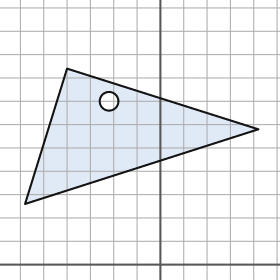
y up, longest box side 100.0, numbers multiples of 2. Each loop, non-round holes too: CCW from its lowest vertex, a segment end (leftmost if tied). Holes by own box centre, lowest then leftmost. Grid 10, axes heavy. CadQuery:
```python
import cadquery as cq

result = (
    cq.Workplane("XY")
    .moveTo(-58.0, 26.0)
    .lineTo(42.0, 58.0)
    .lineTo(-40.0, 84.0)
    .close()
    .moveTo(-22.0, 70.0)
    .circle(4.0)
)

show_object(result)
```